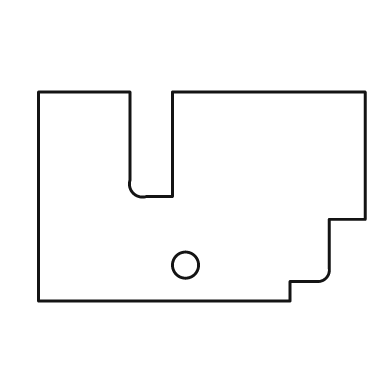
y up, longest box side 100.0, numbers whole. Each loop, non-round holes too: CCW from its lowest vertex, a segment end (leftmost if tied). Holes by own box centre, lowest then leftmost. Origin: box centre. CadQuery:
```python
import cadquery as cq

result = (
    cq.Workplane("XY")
    .moveTo(-50.0, -32.0)
    .lineTo(27.0, -32.0)
    .lineTo(27.0, -26.0)
    .lineTo(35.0, -26.0)
    .threePointArc((38.0, -25.0), (39.0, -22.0))
    .lineTo(39.0, -7.0)
    .lineTo(50.0, -7.0)
    .lineTo(50.0, 32.0)
    .lineTo(-9.0, 32.0)
    .lineTo(-9.0, 0.0)
    .lineTo(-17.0, 0.0)
    .threePointArc((-21.0, 1.0), (-22.0, 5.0))
    .lineTo(-22.0, 32.0)
    .lineTo(-50.0, 32.0)
    .close()
    .moveTo(-5.0, -21.0)
    .circle(4.0)
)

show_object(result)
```